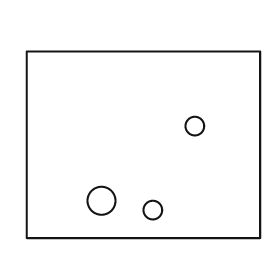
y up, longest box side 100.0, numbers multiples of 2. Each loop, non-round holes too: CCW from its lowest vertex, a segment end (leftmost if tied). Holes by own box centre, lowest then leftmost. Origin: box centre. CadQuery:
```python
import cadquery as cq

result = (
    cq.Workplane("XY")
    .moveTo(-50.0, -40.0)
    .lineTo(50.0, -40.0)
    .lineTo(50.0, 40.0)
    .lineTo(-50.0, 40.0)
    .close()
    .moveTo(4.0, -28.0)
    .circle(4.0)
    .moveTo(-18.0, -24.0)
    .circle(6.0)
    .moveTo(22.0, 8.0)
    .circle(4.0)
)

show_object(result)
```